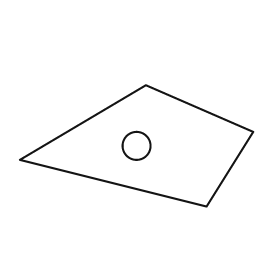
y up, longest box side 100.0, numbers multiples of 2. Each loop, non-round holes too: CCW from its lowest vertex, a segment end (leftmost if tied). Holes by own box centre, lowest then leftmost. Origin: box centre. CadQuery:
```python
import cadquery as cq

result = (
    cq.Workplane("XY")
    .moveTo(30.0, -26.0)
    .lineTo(50.0, 6.0)
    .lineTo(4.0, 26.0)
    .lineTo(-50.0, -6.0)
    .close()
    .moveTo(0.0, 0.0)
    .circle(6.0)
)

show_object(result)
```